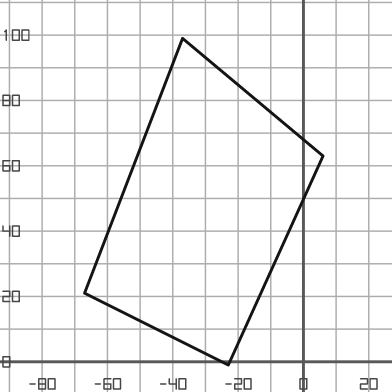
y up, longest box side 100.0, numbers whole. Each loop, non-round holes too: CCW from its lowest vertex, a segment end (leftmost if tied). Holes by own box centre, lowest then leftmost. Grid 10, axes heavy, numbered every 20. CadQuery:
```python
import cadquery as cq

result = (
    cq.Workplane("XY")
    .moveTo(-23.0, -1.0)
    .lineTo(6.0, 63.0)
    .lineTo(-37.0, 99.0)
    .lineTo(-67.0, 21.0)
    .close()
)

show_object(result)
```